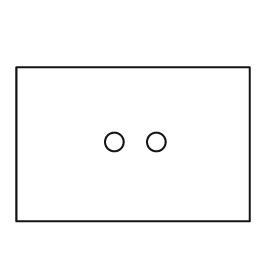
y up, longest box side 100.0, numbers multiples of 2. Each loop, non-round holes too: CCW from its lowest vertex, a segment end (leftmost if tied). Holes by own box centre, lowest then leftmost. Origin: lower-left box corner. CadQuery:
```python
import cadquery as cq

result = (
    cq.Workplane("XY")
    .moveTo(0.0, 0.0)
    .lineTo(100.0, 0.0)
    .lineTo(100.0, 66.0)
    .lineTo(0.0, 66.0)
    .close()
    .moveTo(42.0, 34.0)
    .circle(4.0)
    .moveTo(60.0, 34.0)
    .circle(4.0)
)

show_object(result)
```